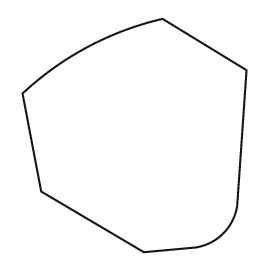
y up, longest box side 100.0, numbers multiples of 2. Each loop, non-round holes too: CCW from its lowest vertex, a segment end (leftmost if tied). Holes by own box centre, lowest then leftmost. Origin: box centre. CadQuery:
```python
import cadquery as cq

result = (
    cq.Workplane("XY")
    .moveTo(4.0, -50.0)
    .lineTo(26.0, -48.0)
    .threePointArc((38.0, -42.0), (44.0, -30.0))
    .lineTo(48.0, 28.0)
    .lineTo(12.0, 50.0)
    .threePointArc((-20.0, 38.0), (-48.0, 18.0))
    .lineTo(-40.0, -24.0)
    .close()
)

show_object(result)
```